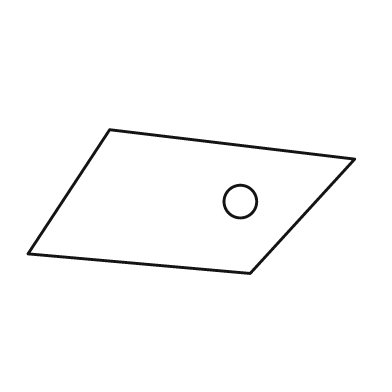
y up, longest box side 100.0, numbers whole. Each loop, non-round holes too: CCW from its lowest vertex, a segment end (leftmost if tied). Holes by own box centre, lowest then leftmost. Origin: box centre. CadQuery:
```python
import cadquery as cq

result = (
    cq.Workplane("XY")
    .moveTo(18.0, -22.0)
    .lineTo(50.0, 13.0)
    .lineTo(-25.0, 22.0)
    .lineTo(-50.0, -16.0)
    .close()
    .moveTo(15.0, 0.0)
    .circle(5.0)
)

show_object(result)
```